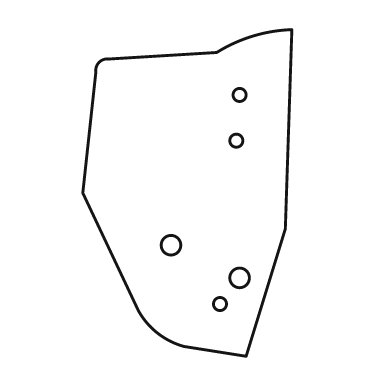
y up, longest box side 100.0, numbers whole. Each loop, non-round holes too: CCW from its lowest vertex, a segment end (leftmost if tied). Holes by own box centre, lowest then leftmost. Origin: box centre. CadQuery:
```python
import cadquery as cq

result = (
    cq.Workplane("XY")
    .moveTo(18.0, -50.0)
    .lineTo(30.0, -11.0)
    .lineTo(32.0, 50.0)
    .threePointArc((20.0, 48.0), (9.0, 43.0))
    .lineTo(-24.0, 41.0)
    .threePointArc((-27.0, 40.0), (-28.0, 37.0))
    .lineTo(-32.0, 0.0)
    .lineTo(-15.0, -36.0)
    .threePointArc((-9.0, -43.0), (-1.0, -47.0))
    .close()
    .moveTo(10.0, -34.0)
    .circle(2.0)
    .moveTo(16.0, -26.0)
    .circle(3.0)
    .moveTo(-5.0, -16.0)
    .circle(3.0)
    .moveTo(15.0, 16.0)
    .circle(2.0)
    .moveTo(16.0, 30.0)
    .circle(2.0)
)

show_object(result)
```